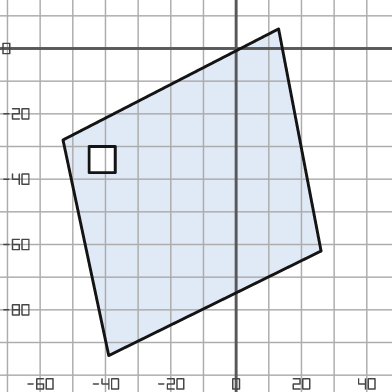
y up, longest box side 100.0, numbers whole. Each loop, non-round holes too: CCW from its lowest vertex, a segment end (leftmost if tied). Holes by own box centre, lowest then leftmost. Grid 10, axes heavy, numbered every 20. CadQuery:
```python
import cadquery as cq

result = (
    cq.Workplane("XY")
    .moveTo(-39.0, -94.0)
    .lineTo(26.0, -62.0)
    .lineTo(13.0, 6.0)
    .lineTo(-53.0, -28.0)
    .close()
    .moveTo(-45.0, -38.0)
    .lineTo(-37.0, -38.0)
    .lineTo(-37.0, -30.0)
    .lineTo(-45.0, -30.0)
    .close()
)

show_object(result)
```